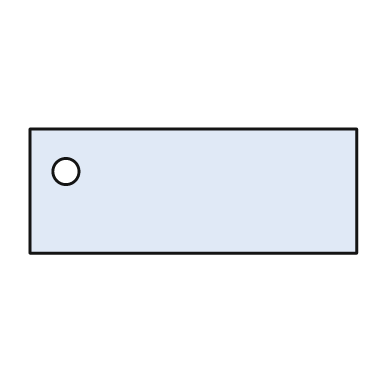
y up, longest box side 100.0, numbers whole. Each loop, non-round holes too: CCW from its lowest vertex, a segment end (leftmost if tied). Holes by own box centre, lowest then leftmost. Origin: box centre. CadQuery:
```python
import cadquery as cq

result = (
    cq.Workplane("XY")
    .moveTo(-50.0, -19.0)
    .lineTo(50.0, -19.0)
    .lineTo(50.0, 19.0)
    .lineTo(-50.0, 19.0)
    .close()
    .moveTo(-39.0, 6.0)
    .circle(4.0)
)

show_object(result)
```